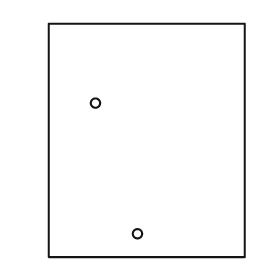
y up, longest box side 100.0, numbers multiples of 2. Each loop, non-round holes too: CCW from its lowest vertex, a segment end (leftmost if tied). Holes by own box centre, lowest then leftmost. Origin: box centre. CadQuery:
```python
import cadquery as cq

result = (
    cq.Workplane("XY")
    .moveTo(-42.0, -50.0)
    .lineTo(42.0, -50.0)
    .lineTo(42.0, 50.0)
    .lineTo(-42.0, 50.0)
    .close()
    .moveTo(-4.0, -40.0)
    .circle(2.0)
    .moveTo(-22.0, 16.0)
    .circle(2.0)
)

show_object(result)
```